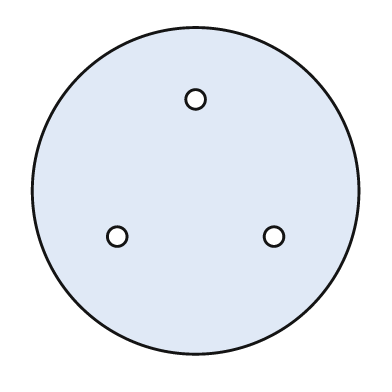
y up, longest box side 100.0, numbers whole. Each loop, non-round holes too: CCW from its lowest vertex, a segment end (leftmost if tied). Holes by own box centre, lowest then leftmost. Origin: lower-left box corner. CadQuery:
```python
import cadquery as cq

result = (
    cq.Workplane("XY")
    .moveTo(50.0, 50.0)
    .circle(50.0)
    .moveTo(26.0, 36.0)
    .circle(3.0)
    .moveTo(74.0, 36.0)
    .circle(3.0)
    .moveTo(50.0, 78.0)
    .circle(3.0)
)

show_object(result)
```